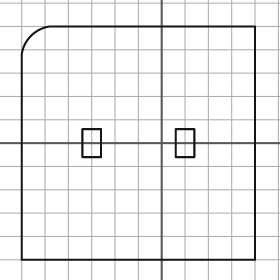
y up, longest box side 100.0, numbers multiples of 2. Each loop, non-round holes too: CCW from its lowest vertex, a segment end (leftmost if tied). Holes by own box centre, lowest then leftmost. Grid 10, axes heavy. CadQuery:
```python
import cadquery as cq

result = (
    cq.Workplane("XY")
    .moveTo(-60.0, -50.0)
    .lineTo(40.0, -50.0)
    .lineTo(40.0, 50.0)
    .lineTo(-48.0, 50.0)
    .threePointArc((-56.0, 46.0), (-60.0, 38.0))
    .close()
    .moveTo(-34.0, -6.0)
    .lineTo(-26.0, -6.0)
    .lineTo(-26.0, 6.0)
    .lineTo(-34.0, 6.0)
    .close()
    .moveTo(6.0, -6.0)
    .lineTo(14.0, -6.0)
    .lineTo(14.0, 6.0)
    .lineTo(6.0, 6.0)
    .close()
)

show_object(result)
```